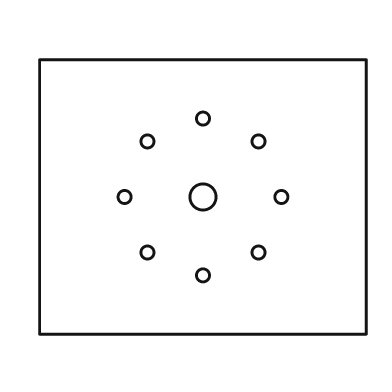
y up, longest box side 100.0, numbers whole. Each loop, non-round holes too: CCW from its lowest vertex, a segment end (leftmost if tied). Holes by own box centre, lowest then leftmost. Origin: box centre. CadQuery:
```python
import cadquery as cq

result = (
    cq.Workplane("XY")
    .moveTo(-50.0, -42.0)
    .lineTo(50.0, -42.0)
    .lineTo(50.0, 42.0)
    .lineTo(-50.0, 42.0)
    .close()
    .moveTo(0.0, -24.0)
    .circle(2.0)
    .moveTo(-17.0, -17.0)
    .circle(2.0)
    .moveTo(17.0, -17.0)
    .circle(2.0)
    .moveTo(-24.0, 0.0)
    .circle(2.0)
    .moveTo(0.0, 0.0)
    .circle(4.0)
    .moveTo(24.0, 0.0)
    .circle(2.0)
    .moveTo(-17.0, 17.0)
    .circle(2.0)
    .moveTo(17.0, 17.0)
    .circle(2.0)
    .moveTo(0.0, 24.0)
    .circle(2.0)
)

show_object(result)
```